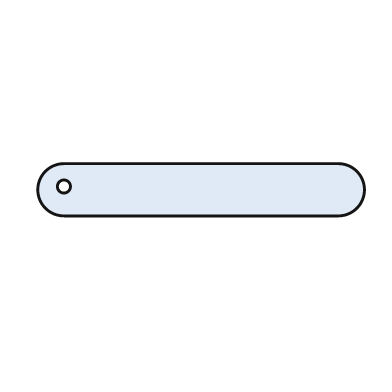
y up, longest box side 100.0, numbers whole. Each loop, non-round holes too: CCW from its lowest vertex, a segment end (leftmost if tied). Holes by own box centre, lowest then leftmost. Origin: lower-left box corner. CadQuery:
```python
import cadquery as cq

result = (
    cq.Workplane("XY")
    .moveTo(8.0, 0.0)
    .lineTo(92.0, 0.0)
    .threePointArc((100.0, 8.0), (92.0, 16.0))
    .lineTo(8.0, 16.0)
    .threePointArc((0.0, 8.0), (8.0, 0.0))
    .close()
    .moveTo(8.0, 9.0)
    .circle(2.0)
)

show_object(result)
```